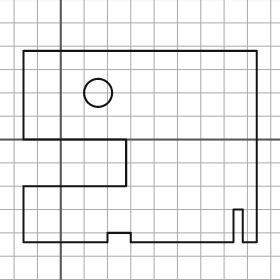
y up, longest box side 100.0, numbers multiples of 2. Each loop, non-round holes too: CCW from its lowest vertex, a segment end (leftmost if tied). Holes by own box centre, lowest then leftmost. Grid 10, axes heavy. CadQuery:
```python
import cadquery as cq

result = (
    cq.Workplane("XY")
    .moveTo(-16.0, -44.0)
    .lineTo(20.0, -44.0)
    .lineTo(20.0, -40.0)
    .lineTo(30.0, -40.0)
    .lineTo(30.0, -44.0)
    .lineTo(74.0, -44.0)
    .lineTo(74.0, -30.0)
    .lineTo(78.0, -30.0)
    .lineTo(78.0, -44.0)
    .lineTo(84.0, -44.0)
    .lineTo(84.0, 38.0)
    .lineTo(-16.0, 38.0)
    .lineTo(-16.0, 0.0)
    .lineTo(28.0, 0.0)
    .lineTo(28.0, -20.0)
    .lineTo(-16.0, -20.0)
    .close()
    .moveTo(16.0, 20.0)
    .circle(6.0)
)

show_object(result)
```